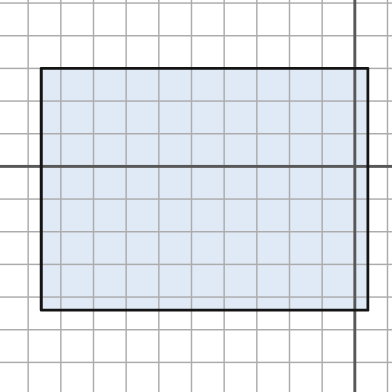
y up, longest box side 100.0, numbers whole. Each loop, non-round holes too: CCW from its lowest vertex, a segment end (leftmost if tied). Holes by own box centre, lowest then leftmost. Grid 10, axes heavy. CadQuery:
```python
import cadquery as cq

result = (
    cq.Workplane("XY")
    .moveTo(-96.0, -44.0)
    .lineTo(4.0, -44.0)
    .lineTo(4.0, 30.0)
    .lineTo(-96.0, 30.0)
    .close()
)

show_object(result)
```